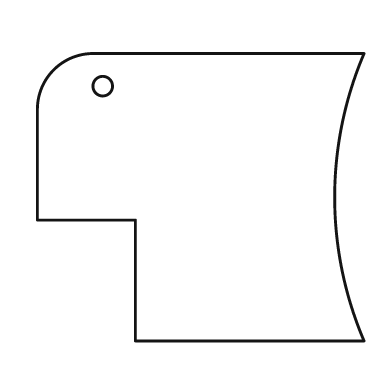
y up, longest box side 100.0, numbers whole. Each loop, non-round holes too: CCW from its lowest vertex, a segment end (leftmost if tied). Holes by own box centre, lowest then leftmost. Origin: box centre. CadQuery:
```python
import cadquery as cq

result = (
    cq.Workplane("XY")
    .moveTo(-20.0, -44.0)
    .lineTo(50.0, -44.0)
    .threePointArc((41.0, 0.0), (50.0, 44.0))
    .lineTo(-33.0, 44.0)
    .threePointArc((-45.0, 39.0), (-50.0, 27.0))
    .lineTo(-50.0, -7.0)
    .lineTo(-20.0, -7.0)
    .close()
    .moveTo(-30.0, 34.0)
    .circle(3.0)
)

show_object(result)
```